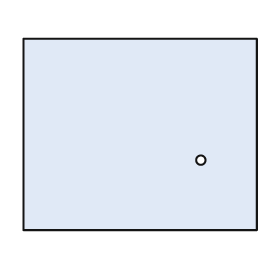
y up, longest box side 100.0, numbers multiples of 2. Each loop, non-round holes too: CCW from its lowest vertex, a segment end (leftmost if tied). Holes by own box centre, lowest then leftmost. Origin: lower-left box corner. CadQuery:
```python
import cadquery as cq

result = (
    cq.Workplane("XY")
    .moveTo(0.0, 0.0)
    .lineTo(100.0, 0.0)
    .lineTo(100.0, 82.0)
    .lineTo(0.0, 82.0)
    .close()
    .moveTo(76.0, 30.0)
    .circle(2.0)
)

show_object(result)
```